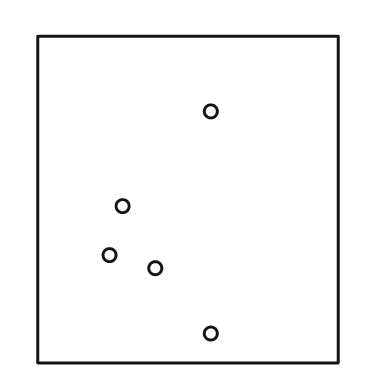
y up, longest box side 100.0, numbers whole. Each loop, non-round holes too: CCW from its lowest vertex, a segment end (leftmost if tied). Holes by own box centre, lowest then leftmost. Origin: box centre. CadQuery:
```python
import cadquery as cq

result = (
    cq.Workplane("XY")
    .moveTo(-46.0, -50.0)
    .lineTo(46.0, -50.0)
    .lineTo(46.0, 50.0)
    .lineTo(-46.0, 50.0)
    .close()
    .moveTo(7.0, -41.0)
    .circle(2.0)
    .moveTo(-10.0, -21.0)
    .circle(2.0)
    .moveTo(-24.0, -17.0)
    .circle(2.0)
    .moveTo(-20.0, -2.0)
    .circle(2.0)
    .moveTo(7.0, 27.0)
    .circle(2.0)
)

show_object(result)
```